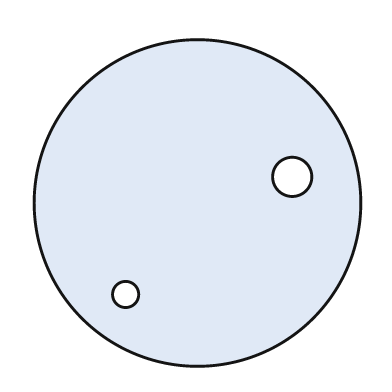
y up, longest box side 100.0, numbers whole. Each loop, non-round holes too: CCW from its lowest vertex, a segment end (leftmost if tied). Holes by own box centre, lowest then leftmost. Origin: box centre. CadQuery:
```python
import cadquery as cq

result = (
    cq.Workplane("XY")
    .moveTo(0.0, 0.0)
    .circle(50.0)
    .moveTo(-22.0, -28.0)
    .circle(4.0)
    .moveTo(29.0, 8.0)
    .circle(6.0)
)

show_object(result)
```